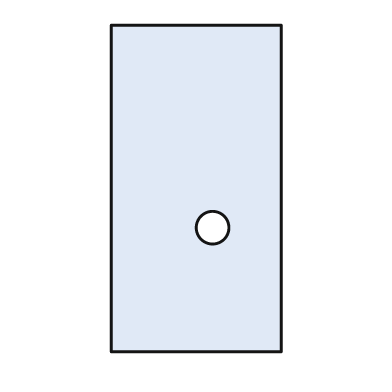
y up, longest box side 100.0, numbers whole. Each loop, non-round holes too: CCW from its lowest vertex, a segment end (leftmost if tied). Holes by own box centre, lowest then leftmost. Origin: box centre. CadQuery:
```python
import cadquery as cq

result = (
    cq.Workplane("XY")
    .moveTo(-26.0, -50.0)
    .lineTo(26.0, -50.0)
    .lineTo(26.0, 50.0)
    .lineTo(-26.0, 50.0)
    .close()
    .moveTo(5.0, -12.0)
    .circle(5.0)
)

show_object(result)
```